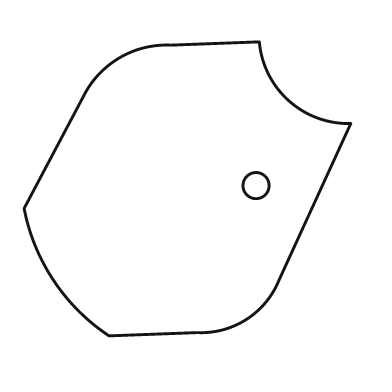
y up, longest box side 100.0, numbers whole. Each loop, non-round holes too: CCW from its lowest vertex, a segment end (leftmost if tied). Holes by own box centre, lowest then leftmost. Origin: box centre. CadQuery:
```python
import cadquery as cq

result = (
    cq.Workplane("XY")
    .moveTo(-24.0, -45.0)
    .lineTo(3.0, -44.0)
    .threePointArc((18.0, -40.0), (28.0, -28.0))
    .lineTo(50.0, 20.0)
    .threePointArc((31.0, 27.0), (22.0, 45.0))
    .lineTo(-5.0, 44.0)
    .threePointArc((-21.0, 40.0), (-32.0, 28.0))
    .lineTo(-50.0, -6.0)
    .threePointArc((-41.0, -28.0), (-24.0, -45.0))
    .close()
    .moveTo(21.0, 1.0)
    .circle(4.0)
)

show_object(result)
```